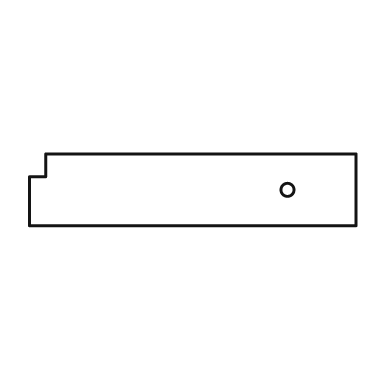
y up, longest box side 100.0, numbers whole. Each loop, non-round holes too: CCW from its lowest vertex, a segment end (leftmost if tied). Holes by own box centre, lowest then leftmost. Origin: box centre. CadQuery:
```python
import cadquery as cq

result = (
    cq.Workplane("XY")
    .moveTo(-50.0, -11.0)
    .lineTo(50.0, -11.0)
    .lineTo(50.0, 11.0)
    .lineTo(-45.0, 11.0)
    .lineTo(-45.0, 4.0)
    .lineTo(-50.0, 4.0)
    .close()
    .moveTo(29.0, 0.0)
    .circle(2.0)
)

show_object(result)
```